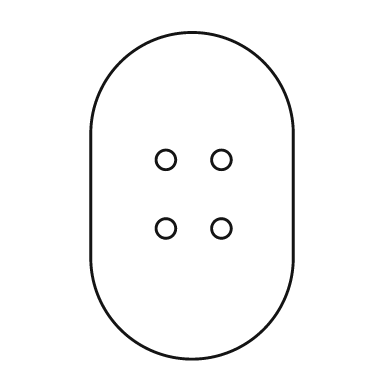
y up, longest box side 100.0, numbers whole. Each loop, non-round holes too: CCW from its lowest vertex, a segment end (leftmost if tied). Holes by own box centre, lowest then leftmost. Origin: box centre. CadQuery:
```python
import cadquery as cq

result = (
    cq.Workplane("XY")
    .moveTo(-31.0, -19.0)
    .threePointArc((0.0, -50.0), (31.0, -19.0))
    .lineTo(31.0, 19.0)
    .threePointArc((0.0, 50.0), (-31.0, 19.0))
    .close()
    .moveTo(-8.0, -10.0)
    .circle(3.0)
    .moveTo(9.0, -10.0)
    .circle(3.0)
    .moveTo(-8.0, 11.0)
    .circle(3.0)
    .moveTo(9.0, 11.0)
    .circle(3.0)
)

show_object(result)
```